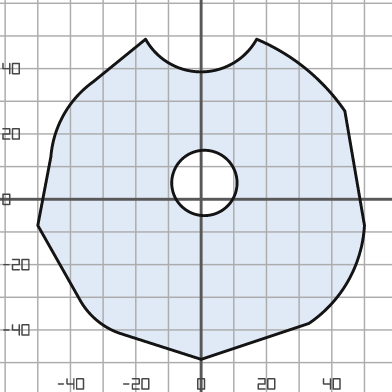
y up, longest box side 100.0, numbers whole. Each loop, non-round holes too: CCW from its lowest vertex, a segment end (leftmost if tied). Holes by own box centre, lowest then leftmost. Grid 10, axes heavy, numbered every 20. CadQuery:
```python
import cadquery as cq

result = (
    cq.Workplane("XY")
    .moveTo(0.0, -49.0)
    .lineTo(33.0, -38.0)
    .threePointArc((45.0, -25.0), (50.0, -8.0))
    .lineTo(44.0, 27.0)
    .threePointArc((32.0, 40.0), (17.0, 49.0))
    .threePointArc((0.0, 39.0), (-17.0, 49.0))
    .lineTo(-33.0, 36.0)
    .threePointArc((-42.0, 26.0), (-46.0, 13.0))
    .lineTo(-50.0, -8.0)
    .lineTo(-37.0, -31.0)
    .threePointArc((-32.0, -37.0), (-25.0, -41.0))
    .close()
    .moveTo(1.0, 5.0)
    .circle(10.0)
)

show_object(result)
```